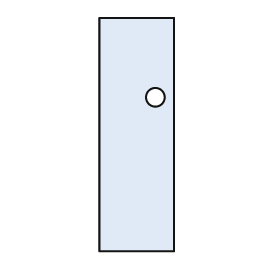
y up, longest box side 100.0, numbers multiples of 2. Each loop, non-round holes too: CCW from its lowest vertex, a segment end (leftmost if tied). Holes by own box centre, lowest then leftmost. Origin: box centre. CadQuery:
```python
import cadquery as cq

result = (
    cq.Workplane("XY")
    .moveTo(-16.0, -50.0)
    .lineTo(16.0, -50.0)
    .lineTo(16.0, 50.0)
    .lineTo(-16.0, 50.0)
    .close()
    .moveTo(8.0, 16.0)
    .circle(4.0)
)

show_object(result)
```